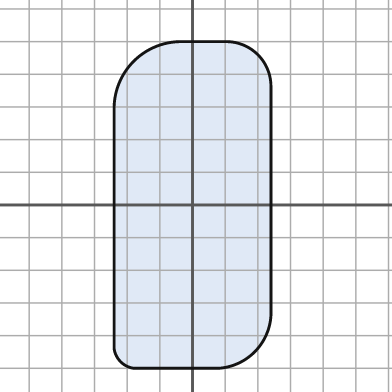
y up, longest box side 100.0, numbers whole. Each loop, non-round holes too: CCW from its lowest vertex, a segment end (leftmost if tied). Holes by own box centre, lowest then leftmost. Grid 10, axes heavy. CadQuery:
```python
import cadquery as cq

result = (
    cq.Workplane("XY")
    .moveTo(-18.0, -50.0)
    .lineTo(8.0, -50.0)
    .threePointArc((19.0, -45.0), (24.0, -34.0))
    .lineTo(24.0, 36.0)
    .threePointArc((20.0, 46.0), (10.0, 50.0))
    .lineTo(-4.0, 50.0)
    .threePointArc((-18.0, 44.0), (-24.0, 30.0))
    .lineTo(-24.0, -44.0)
    .threePointArc((-22.0, -48.0), (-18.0, -50.0))
    .close()
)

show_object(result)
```